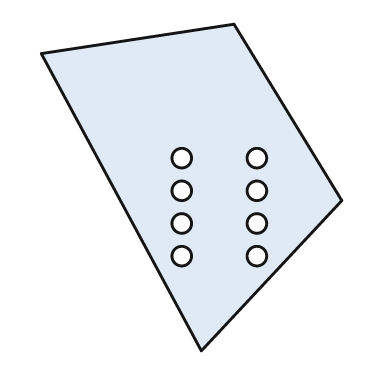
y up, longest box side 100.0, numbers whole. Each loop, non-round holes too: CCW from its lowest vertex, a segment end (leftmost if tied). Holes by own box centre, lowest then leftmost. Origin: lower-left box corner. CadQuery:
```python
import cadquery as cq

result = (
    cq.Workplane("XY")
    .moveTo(49.0, 0.0)
    .lineTo(92.0, 46.0)
    .lineTo(59.0, 100.0)
    .lineTo(0.0, 91.0)
    .close()
    .moveTo(43.0, 29.0)
    .circle(3.0)
    .moveTo(66.0, 29.0)
    .circle(3.0)
    .moveTo(43.0, 39.0)
    .circle(3.0)
    .moveTo(66.0, 39.0)
    .circle(3.0)
    .moveTo(43.0, 49.0)
    .circle(3.0)
    .moveTo(66.0, 49.0)
    .circle(3.0)
    .moveTo(43.0, 59.0)
    .circle(3.0)
    .moveTo(66.0, 59.0)
    .circle(3.0)
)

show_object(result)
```